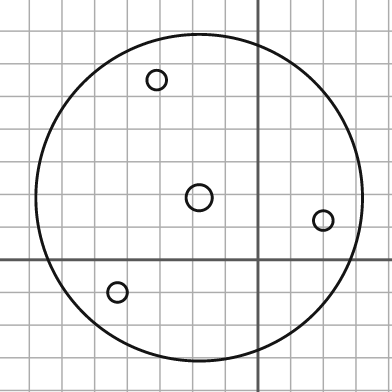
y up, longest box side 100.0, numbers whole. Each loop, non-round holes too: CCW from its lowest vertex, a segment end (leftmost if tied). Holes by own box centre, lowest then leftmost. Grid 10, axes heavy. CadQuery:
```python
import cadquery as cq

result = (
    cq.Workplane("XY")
    .moveTo(-18.0, 19.0)
    .circle(50.0)
    .moveTo(-43.0, -10.0)
    .circle(3.0)
    .moveTo(20.0, 12.0)
    .circle(3.0)
    .moveTo(-18.0, 19.0)
    .circle(4.0)
    .moveTo(-31.0, 55.0)
    .circle(3.0)
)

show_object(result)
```